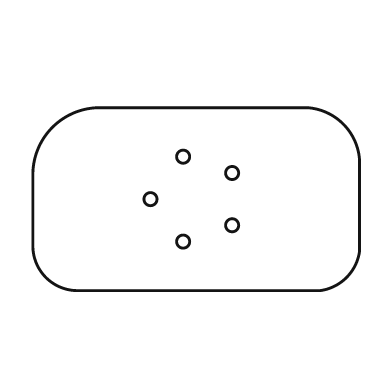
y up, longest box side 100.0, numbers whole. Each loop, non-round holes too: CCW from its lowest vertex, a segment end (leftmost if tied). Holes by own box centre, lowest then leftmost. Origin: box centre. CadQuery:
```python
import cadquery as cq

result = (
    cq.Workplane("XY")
    .moveTo(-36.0, -28.0)
    .lineTo(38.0, -28.0)
    .threePointArc((46.0, -24.0), (50.0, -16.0))
    .lineTo(50.0, 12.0)
    .threePointArc((45.0, 23.0), (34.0, 28.0))
    .lineTo(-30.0, 28.0)
    .threePointArc((-44.0, 22.0), (-50.0, 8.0))
    .lineTo(-50.0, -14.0)
    .threePointArc((-46.0, -24.0), (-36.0, -28.0))
    .close()
    .moveTo(-4.0, -13.0)
    .circle(2.0)
    .moveTo(11.0, -8.0)
    .circle(2.0)
    .moveTo(-14.0, 0.0)
    .circle(2.0)
    .moveTo(11.0, 8.0)
    .circle(2.0)
    .moveTo(-4.0, 13.0)
    .circle(2.0)
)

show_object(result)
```